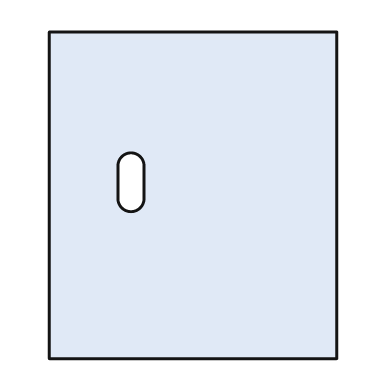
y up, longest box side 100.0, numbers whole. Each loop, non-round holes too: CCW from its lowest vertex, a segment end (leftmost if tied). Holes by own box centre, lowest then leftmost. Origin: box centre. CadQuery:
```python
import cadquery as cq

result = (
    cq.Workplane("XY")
    .moveTo(-44.0, -50.0)
    .lineTo(44.0, -50.0)
    .lineTo(44.0, 50.0)
    .lineTo(-44.0, 50.0)
    .close()
    .moveTo(-23.0, -1.0)
    .threePointArc((-19.0, -5.0), (-15.0, -1.0))
    .lineTo(-15.0, 9.0)
    .threePointArc((-19.0, 13.0), (-23.0, 9.0))
    .close()
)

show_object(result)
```